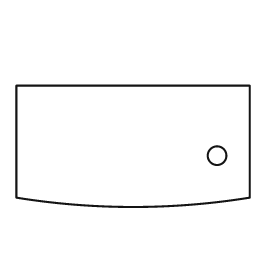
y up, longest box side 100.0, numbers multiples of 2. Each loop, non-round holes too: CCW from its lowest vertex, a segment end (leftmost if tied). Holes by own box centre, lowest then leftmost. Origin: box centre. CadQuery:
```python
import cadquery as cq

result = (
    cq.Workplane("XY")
    .moveTo(-50.0, -22.0)
    .threePointArc((0.0, -26.0), (50.0, -22.0))
    .lineTo(50.0, 26.0)
    .lineTo(-50.0, 26.0)
    .close()
    .moveTo(36.0, -4.0)
    .circle(4.0)
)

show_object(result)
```